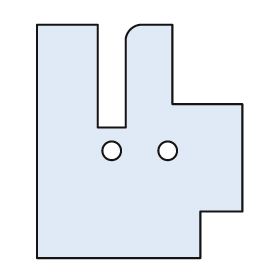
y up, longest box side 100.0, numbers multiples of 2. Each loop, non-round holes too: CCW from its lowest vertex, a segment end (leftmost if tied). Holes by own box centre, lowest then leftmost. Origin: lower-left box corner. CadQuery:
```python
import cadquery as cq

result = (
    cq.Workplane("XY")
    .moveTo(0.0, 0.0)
    .lineTo(70.0, 0.0)
    .lineTo(70.0, 20.0)
    .lineTo(88.0, 20.0)
    .lineTo(88.0, 66.0)
    .lineTo(58.0, 66.0)
    .lineTo(58.0, 100.0)
    .lineTo(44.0, 100.0)
    .threePointArc((40.0, 98.0), (38.0, 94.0))
    .lineTo(38.0, 56.0)
    .lineTo(26.0, 56.0)
    .lineTo(26.0, 100.0)
    .lineTo(0.0, 100.0)
    .close()
    .moveTo(32.0, 46.0)
    .circle(4.0)
    .moveTo(56.0, 46.0)
    .circle(4.0)
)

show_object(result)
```